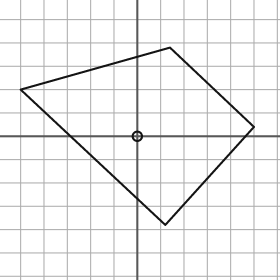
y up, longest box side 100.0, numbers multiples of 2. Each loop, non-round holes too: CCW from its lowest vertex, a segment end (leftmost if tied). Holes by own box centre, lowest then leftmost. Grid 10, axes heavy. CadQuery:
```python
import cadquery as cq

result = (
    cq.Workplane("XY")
    .moveTo(12.0, -38.0)
    .lineTo(50.0, 4.0)
    .lineTo(14.0, 38.0)
    .lineTo(-50.0, 20.0)
    .close()
    .moveTo(0.0, 0.0)
    .circle(2.0)
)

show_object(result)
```